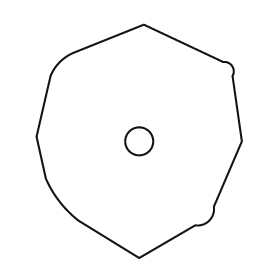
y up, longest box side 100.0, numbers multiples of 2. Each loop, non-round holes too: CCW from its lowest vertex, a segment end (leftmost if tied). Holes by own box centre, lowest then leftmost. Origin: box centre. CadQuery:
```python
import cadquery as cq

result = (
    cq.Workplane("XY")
    .moveTo(0.0, -50.0)
    .lineTo(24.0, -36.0)
    .threePointArc((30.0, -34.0), (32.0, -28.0))
    .lineTo(44.0, 0.0)
    .lineTo(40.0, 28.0)
    .threePointArc((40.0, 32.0), (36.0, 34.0))
    .lineTo(2.0, 50.0)
    .lineTo(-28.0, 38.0)
    .threePointArc((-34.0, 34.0), (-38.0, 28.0))
    .lineTo(-44.0, 2.0)
    .lineTo(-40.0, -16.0)
    .threePointArc((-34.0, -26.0), (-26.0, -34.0))
    .close()
    .moveTo(0.0, 0.0)
    .circle(6.0)
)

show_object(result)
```